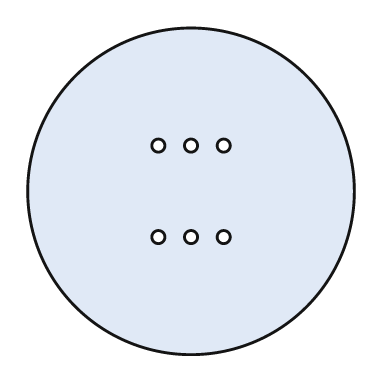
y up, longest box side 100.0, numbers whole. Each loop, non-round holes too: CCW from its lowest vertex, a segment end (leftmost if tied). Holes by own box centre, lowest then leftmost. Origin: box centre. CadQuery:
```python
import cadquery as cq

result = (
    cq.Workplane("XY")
    .moveTo(0.0, 0.0)
    .circle(50.0)
    .moveTo(-10.0, -14.0)
    .circle(2.0)
    .moveTo(0.0, -14.0)
    .circle(2.0)
    .moveTo(10.0, -14.0)
    .circle(2.0)
    .moveTo(-10.0, 14.0)
    .circle(2.0)
    .moveTo(0.0, 14.0)
    .circle(2.0)
    .moveTo(10.0, 14.0)
    .circle(2.0)
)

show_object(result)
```